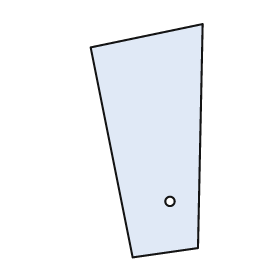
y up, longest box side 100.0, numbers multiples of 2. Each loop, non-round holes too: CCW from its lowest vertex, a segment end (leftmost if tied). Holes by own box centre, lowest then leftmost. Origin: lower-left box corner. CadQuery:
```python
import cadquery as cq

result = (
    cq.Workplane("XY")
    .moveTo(18.0, 0.0)
    .lineTo(46.0, 4.0)
    .lineTo(48.0, 100.0)
    .lineTo(0.0, 90.0)
    .close()
    .moveTo(34.0, 24.0)
    .circle(2.0)
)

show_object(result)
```